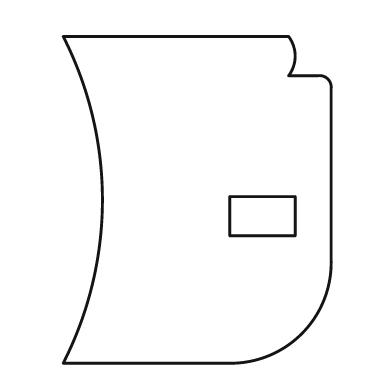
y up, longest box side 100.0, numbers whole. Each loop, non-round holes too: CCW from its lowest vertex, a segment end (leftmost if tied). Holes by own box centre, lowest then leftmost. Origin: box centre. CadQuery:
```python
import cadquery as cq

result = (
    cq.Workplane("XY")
    .moveTo(-41.0, -50.0)
    .lineTo(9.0, -50.0)
    .threePointArc((32.0, -41.0), (41.0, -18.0))
    .lineTo(41.0, 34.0)
    .threePointArc((40.0, 37.0), (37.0, 38.0))
    .lineTo(28.0, 38.0)
    .threePointArc((30.0, 44.0), (28.0, 50.0))
    .lineTo(-41.0, 50.0)
    .threePointArc((-29.0, 0.0), (-41.0, -50.0))
    .close()
    .moveTo(10.0, -11.0)
    .lineTo(30.0, -11.0)
    .lineTo(30.0, 1.0)
    .lineTo(10.0, 1.0)
    .close()
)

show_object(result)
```